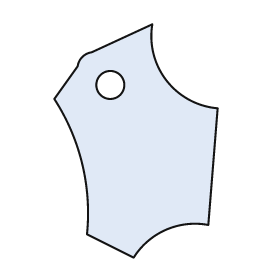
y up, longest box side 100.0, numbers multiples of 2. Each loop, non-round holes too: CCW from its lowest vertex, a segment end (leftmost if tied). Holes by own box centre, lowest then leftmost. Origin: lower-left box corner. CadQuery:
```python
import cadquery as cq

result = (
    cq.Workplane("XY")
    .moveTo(34.0, 0.0)
    .threePointArc((48.0, 12.0), (66.0, 14.0))
    .lineTo(70.0, 64.0)
    .threePointArc((48.0, 76.0), (42.0, 100.0))
    .lineTo(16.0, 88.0)
    .threePointArc((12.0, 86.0), (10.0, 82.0))
    .lineTo(0.0, 68.0)
    .threePointArc((12.0, 40.0), (14.0, 10.0))
    .close()
    .moveTo(24.0, 74.0)
    .circle(6.0)
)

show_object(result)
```